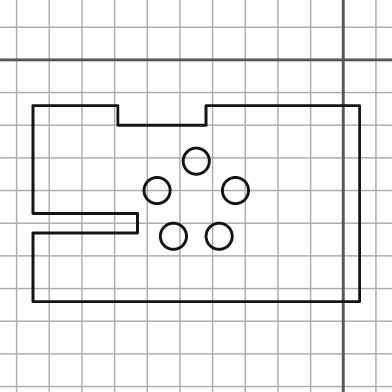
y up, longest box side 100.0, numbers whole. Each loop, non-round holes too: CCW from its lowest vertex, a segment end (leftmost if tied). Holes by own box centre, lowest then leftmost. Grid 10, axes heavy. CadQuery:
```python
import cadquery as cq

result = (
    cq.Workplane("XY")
    .moveTo(-95.0, -74.0)
    .lineTo(5.0, -74.0)
    .lineTo(5.0, -14.0)
    .lineTo(-42.0, -14.0)
    .lineTo(-42.0, -20.0)
    .lineTo(-69.0, -20.0)
    .lineTo(-69.0, -14.0)
    .lineTo(-95.0, -14.0)
    .lineTo(-95.0, -47.0)
    .lineTo(-63.0, -47.0)
    .lineTo(-63.0, -53.0)
    .lineTo(-95.0, -53.0)
    .close()
    .moveTo(-52.0, -54.0)
    .circle(4.0)
    .moveTo(-38.0, -54.0)
    .circle(4.0)
    .moveTo(-57.0, -40.0)
    .circle(4.0)
    .moveTo(-33.0, -40.0)
    .circle(4.0)
    .moveTo(-45.0, -31.0)
    .circle(4.0)
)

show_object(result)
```